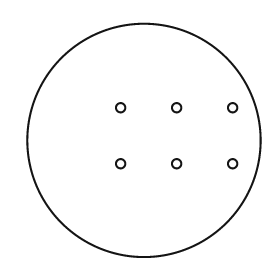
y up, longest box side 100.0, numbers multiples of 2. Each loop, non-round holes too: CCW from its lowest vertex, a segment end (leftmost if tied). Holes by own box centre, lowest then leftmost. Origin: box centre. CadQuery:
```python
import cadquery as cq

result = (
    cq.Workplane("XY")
    .moveTo(0.0, 0.0)
    .circle(50.0)
    .moveTo(-10.0, -10.0)
    .circle(2.0)
    .moveTo(14.0, -10.0)
    .circle(2.0)
    .moveTo(38.0, -10.0)
    .circle(2.0)
    .moveTo(-10.0, 14.0)
    .circle(2.0)
    .moveTo(14.0, 14.0)
    .circle(2.0)
    .moveTo(38.0, 14.0)
    .circle(2.0)
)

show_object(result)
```